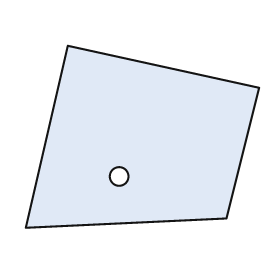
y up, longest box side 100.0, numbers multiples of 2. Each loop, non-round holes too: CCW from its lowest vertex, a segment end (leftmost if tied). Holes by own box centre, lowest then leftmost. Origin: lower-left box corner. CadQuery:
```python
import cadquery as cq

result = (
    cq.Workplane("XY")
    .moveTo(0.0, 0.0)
    .lineTo(86.0, 4.0)
    .lineTo(100.0, 60.0)
    .lineTo(18.0, 78.0)
    .close()
    .moveTo(40.0, 22.0)
    .circle(4.0)
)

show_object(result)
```